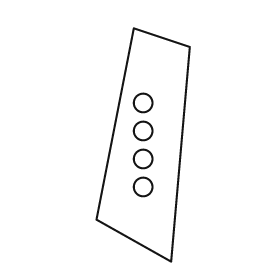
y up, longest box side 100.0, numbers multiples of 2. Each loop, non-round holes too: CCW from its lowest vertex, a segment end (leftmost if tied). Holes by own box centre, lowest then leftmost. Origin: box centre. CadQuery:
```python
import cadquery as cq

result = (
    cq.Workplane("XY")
    .moveTo(12.0, -50.0)
    .lineTo(20.0, 42.0)
    .lineTo(-4.0, 50.0)
    .lineTo(-20.0, -32.0)
    .close()
    .moveTo(0.0, -18.0)
    .circle(4.0)
    .moveTo(0.0, -6.0)
    .circle(4.0)
    .moveTo(0.0, 6.0)
    .circle(4.0)
    .moveTo(0.0, 18.0)
    .circle(4.0)
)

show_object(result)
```